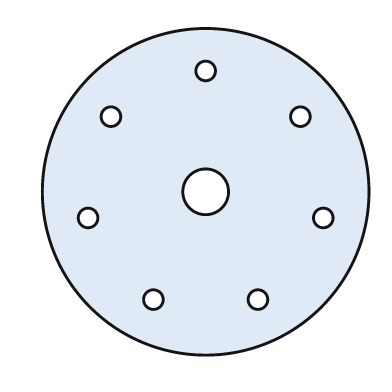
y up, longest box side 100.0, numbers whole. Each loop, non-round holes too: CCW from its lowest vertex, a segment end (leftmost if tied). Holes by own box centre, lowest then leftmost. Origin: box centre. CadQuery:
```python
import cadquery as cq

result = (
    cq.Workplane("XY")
    .moveTo(0.0, 0.0)
    .circle(50.0)
    .moveTo(-16.0, -33.0)
    .circle(3.0)
    .moveTo(16.0, -33.0)
    .circle(3.0)
    .moveTo(-36.0, -8.0)
    .circle(3.0)
    .moveTo(36.0, -8.0)
    .circle(3.0)
    .moveTo(0.0, 0.0)
    .circle(7.0)
    .moveTo(-29.0, 23.0)
    .circle(3.0)
    .moveTo(29.0, 23.0)
    .circle(3.0)
    .moveTo(0.0, 37.0)
    .circle(3.0)
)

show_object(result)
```